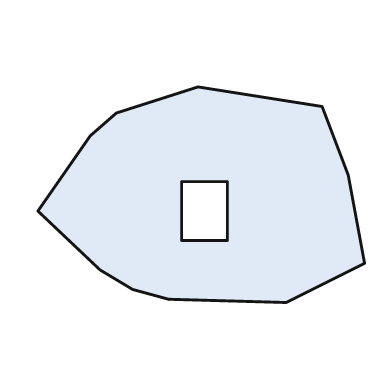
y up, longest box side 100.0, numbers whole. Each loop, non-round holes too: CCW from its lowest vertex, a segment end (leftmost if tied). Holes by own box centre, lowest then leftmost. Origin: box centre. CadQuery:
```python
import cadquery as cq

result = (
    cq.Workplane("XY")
    .moveTo(26.0, -33.0)
    .lineTo(50.0, -21.0)
    .lineTo(45.0, 6.0)
    .lineTo(37.0, 27.0)
    .lineTo(-1.0, 33.0)
    .lineTo(-26.0, 25.0)
    .lineTo(-34.0, 18.0)
    .lineTo(-50.0, -5.0)
    .lineTo(-31.0, -23.0)
    .lineTo(-21.0, -29.0)
    .lineTo(-10.0, -32.0)
    .close()
    .moveTo(-6.0, -14.0)
    .lineTo(8.0, -14.0)
    .lineTo(8.0, 4.0)
    .lineTo(-6.0, 4.0)
    .close()
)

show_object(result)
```